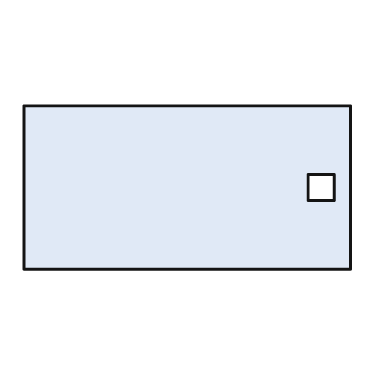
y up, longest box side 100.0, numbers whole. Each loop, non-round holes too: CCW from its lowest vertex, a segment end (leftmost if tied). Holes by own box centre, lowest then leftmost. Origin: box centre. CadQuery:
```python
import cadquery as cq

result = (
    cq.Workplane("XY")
    .moveTo(-50.0, -25.0)
    .lineTo(50.0, -25.0)
    .lineTo(50.0, 25.0)
    .lineTo(-50.0, 25.0)
    .close()
    .moveTo(37.0, -4.0)
    .lineTo(45.0, -4.0)
    .lineTo(45.0, 4.0)
    .lineTo(37.0, 4.0)
    .close()
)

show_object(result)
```